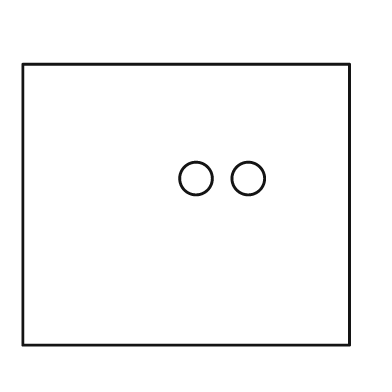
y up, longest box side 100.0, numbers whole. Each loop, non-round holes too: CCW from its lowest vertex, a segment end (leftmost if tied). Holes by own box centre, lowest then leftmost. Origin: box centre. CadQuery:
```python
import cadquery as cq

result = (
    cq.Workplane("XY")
    .moveTo(-50.0, -43.0)
    .lineTo(50.0, -43.0)
    .lineTo(50.0, 43.0)
    .lineTo(-50.0, 43.0)
    .close()
    .moveTo(3.0, 8.0)
    .circle(5.0)
    .moveTo(19.0, 8.0)
    .circle(5.0)
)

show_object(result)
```